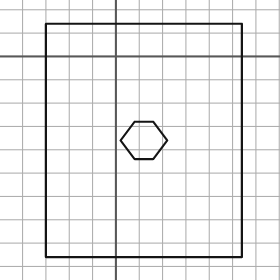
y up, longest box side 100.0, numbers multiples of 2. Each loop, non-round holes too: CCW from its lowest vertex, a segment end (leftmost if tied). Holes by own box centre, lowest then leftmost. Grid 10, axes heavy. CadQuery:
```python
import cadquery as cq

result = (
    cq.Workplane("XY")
    .moveTo(-30.0, -86.0)
    .lineTo(54.0, -86.0)
    .lineTo(54.0, 14.0)
    .lineTo(-30.0, 14.0)
    .close()
    .moveTo(8.0, -44.0)
    .lineTo(16.0, -44.0)
    .lineTo(22.0, -36.0)
    .lineTo(16.0, -28.0)
    .lineTo(8.0, -28.0)
    .lineTo(2.0, -36.0)
    .close()
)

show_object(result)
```